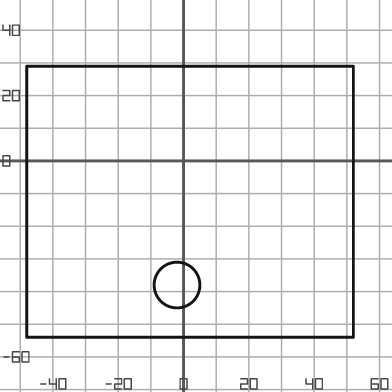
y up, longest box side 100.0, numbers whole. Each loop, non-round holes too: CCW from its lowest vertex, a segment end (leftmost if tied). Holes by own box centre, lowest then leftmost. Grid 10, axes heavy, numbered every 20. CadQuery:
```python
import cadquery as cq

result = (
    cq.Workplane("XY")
    .moveTo(-48.0, -54.0)
    .lineTo(52.0, -54.0)
    .lineTo(52.0, 29.0)
    .lineTo(-48.0, 29.0)
    .close()
    .moveTo(-2.0, -38.0)
    .circle(7.0)
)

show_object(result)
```